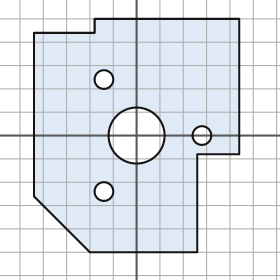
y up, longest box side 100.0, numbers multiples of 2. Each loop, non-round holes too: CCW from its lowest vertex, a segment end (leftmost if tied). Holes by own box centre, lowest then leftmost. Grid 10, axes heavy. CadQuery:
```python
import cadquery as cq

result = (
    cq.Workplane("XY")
    .moveTo(-20.0, -50.0)
    .lineTo(26.0, -50.0)
    .lineTo(26.0, -8.0)
    .lineTo(44.0, -8.0)
    .lineTo(44.0, 50.0)
    .lineTo(-18.0, 50.0)
    .lineTo(-18.0, 44.0)
    .lineTo(-44.0, 44.0)
    .lineTo(-44.0, -26.0)
    .close()
    .moveTo(-14.0, -24.0)
    .circle(4.0)
    .moveTo(0.0, 0.0)
    .circle(12.0)
    .moveTo(28.0, 0.0)
    .circle(4.0)
    .moveTo(-14.0, 24.0)
    .circle(4.0)
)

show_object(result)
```